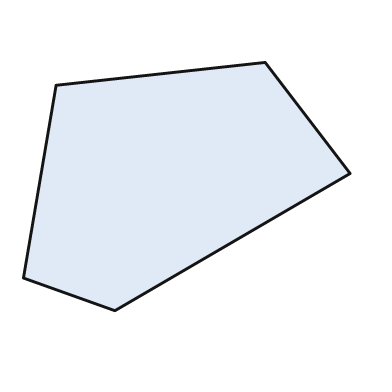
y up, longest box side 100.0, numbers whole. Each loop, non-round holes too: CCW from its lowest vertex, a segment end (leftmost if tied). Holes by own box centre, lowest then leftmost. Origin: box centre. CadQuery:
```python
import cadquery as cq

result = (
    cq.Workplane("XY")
    .moveTo(-22.0, -38.0)
    .lineTo(50.0, 4.0)
    .lineTo(24.0, 38.0)
    .lineTo(-40.0, 31.0)
    .lineTo(-50.0, -28.0)
    .close()
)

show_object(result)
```